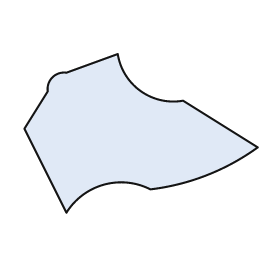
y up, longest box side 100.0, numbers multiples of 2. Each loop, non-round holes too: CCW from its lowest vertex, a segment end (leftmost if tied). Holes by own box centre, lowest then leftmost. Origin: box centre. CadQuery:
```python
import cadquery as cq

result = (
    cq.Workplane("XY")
    .moveTo(-32.0, -34.0)
    .threePointArc((-16.0, -22.0), (4.0, -24.0))
    .threePointArc((28.0, -18.0), (50.0, -6.0))
    .lineTo(18.0, 14.0)
    .threePointArc((0.0, 18.0), (-10.0, 34.0))
    .lineTo(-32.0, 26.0)
    .threePointArc((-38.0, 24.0), (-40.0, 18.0))
    .lineTo(-50.0, 2.0)
    .close()
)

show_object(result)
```